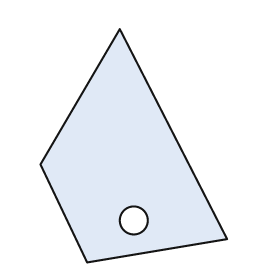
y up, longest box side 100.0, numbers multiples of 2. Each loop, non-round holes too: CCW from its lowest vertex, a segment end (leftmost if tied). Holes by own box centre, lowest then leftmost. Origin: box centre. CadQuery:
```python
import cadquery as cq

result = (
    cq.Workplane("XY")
    .moveTo(-20.0, -50.0)
    .lineTo(40.0, -40.0)
    .lineTo(-6.0, 50.0)
    .lineTo(-40.0, -8.0)
    .close()
    .moveTo(0.0, -32.0)
    .circle(6.0)
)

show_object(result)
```